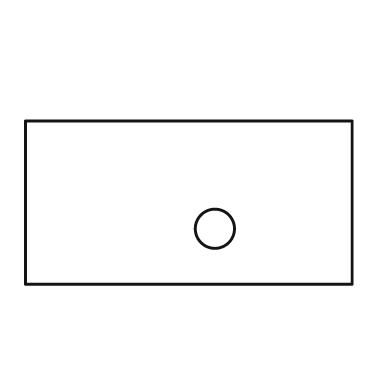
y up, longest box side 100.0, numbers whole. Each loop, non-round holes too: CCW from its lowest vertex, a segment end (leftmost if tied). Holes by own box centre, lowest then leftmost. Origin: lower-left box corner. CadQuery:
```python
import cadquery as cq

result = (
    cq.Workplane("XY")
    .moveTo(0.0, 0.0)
    .lineTo(100.0, 0.0)
    .lineTo(100.0, 50.0)
    .lineTo(0.0, 50.0)
    .close()
    .moveTo(58.0, 17.0)
    .circle(6.0)
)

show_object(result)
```